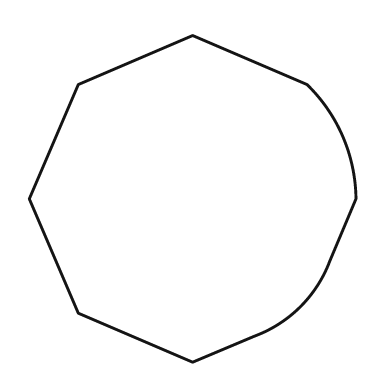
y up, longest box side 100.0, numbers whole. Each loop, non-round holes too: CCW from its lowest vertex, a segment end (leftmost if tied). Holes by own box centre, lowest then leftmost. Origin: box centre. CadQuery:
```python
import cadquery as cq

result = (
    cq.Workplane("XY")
    .moveTo(0.0, -50.0)
    .lineTo(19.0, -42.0)
    .threePointArc((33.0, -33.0), (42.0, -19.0))
    .lineTo(50.0, 0.0)
    .threePointArc((46.0, 19.0), (35.0, 35.0))
    .lineTo(0.0, 50.0)
    .lineTo(-35.0, 35.0)
    .lineTo(-50.0, 0.0)
    .lineTo(-35.0, -35.0)
    .close()
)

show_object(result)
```